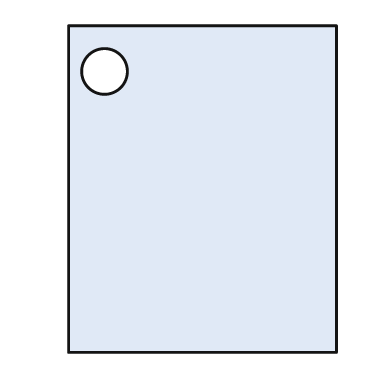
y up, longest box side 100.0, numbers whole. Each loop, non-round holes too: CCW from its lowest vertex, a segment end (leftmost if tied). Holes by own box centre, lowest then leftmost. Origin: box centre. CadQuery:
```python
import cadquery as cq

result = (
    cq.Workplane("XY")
    .moveTo(-41.0, -50.0)
    .lineTo(41.0, -50.0)
    .lineTo(41.0, 50.0)
    .lineTo(-41.0, 50.0)
    .close()
    .moveTo(-30.0, 36.0)
    .circle(7.0)
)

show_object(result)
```